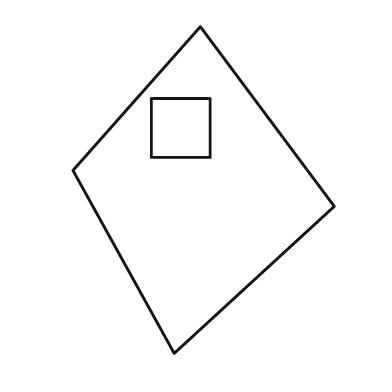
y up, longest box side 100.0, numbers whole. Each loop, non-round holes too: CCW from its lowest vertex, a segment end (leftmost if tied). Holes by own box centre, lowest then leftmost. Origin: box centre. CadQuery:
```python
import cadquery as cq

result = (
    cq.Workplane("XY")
    .moveTo(-9.0, -50.0)
    .lineTo(40.0, -5.0)
    .lineTo(-1.0, 50.0)
    .lineTo(-40.0, 6.0)
    .close()
    .moveTo(-16.0, 10.0)
    .lineTo(2.0, 10.0)
    .lineTo(2.0, 28.0)
    .lineTo(-16.0, 28.0)
    .close()
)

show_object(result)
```